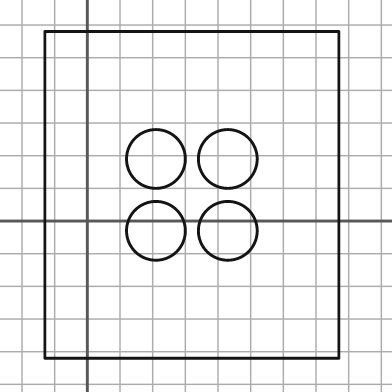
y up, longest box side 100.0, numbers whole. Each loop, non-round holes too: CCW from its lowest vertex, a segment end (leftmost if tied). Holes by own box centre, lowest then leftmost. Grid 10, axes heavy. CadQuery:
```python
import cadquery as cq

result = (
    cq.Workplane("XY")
    .moveTo(-13.0, -42.0)
    .lineTo(77.0, -42.0)
    .lineTo(77.0, 58.0)
    .lineTo(-13.0, 58.0)
    .close()
    .moveTo(21.0, -3.0)
    .circle(9.0)
    .moveTo(43.0, -3.0)
    .circle(9.0)
    .moveTo(21.0, 19.0)
    .circle(9.0)
    .moveTo(43.0, 19.0)
    .circle(9.0)
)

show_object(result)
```